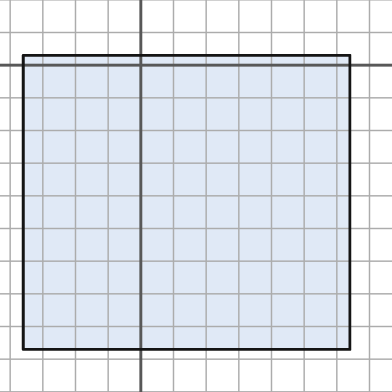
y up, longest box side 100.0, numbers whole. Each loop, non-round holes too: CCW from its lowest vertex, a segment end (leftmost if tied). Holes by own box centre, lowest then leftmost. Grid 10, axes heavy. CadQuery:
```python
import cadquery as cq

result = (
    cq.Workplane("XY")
    .moveTo(-36.0, -87.0)
    .lineTo(64.0, -87.0)
    .lineTo(64.0, 3.0)
    .lineTo(-36.0, 3.0)
    .close()
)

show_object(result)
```